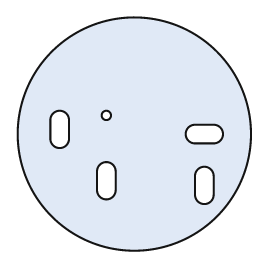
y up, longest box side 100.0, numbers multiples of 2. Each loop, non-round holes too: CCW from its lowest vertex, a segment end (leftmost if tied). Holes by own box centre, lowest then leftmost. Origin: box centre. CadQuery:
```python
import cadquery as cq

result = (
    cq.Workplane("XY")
    .moveTo(0.0, 0.0)
    .circle(50.0)
    .moveTo(26.0, -26.0)
    .threePointArc((30.0, -30.0), (34.0, -26.0))
    .lineTo(34.0, -18.0)
    .threePointArc((30.0, -14.0), (26.0, -18.0))
    .close()
    .moveTo(-16.0, -24.0)
    .threePointArc((-12.0, -28.0), (-8.0, -24.0))
    .lineTo(-8.0, -16.0)
    .threePointArc((-12.0, -12.0), (-16.0, -16.0))
    .close()
    .moveTo(26.0, -4.0)
    .lineTo(34.0, -4.0)
    .threePointArc((38.0, 0.0), (34.0, 4.0))
    .lineTo(26.0, 4.0)
    .threePointArc((22.0, 0.0), (26.0, -4.0))
    .close()
    .moveTo(-36.0, -2.0)
    .threePointArc((-32.0, -6.0), (-28.0, -2.0))
    .lineTo(-28.0, 6.0)
    .threePointArc((-32.0, 10.0), (-36.0, 6.0))
    .close()
    .moveTo(-12.0, 8.0)
    .circle(2.0)
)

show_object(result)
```